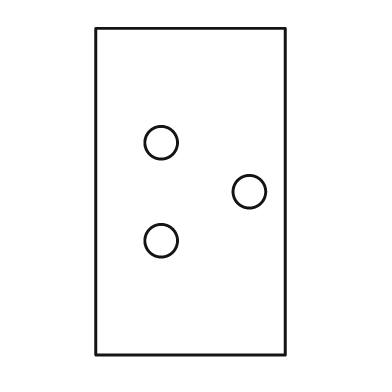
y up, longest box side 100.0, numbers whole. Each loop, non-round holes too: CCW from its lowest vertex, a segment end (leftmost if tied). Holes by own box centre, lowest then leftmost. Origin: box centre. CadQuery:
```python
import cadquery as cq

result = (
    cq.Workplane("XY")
    .moveTo(-29.0, -50.0)
    .lineTo(29.0, -50.0)
    .lineTo(29.0, 50.0)
    .lineTo(-29.0, 50.0)
    .close()
    .moveTo(-9.0, -15.0)
    .circle(5.0)
    .moveTo(18.0, 0.0)
    .circle(5.0)
    .moveTo(-9.0, 15.0)
    .circle(5.0)
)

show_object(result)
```